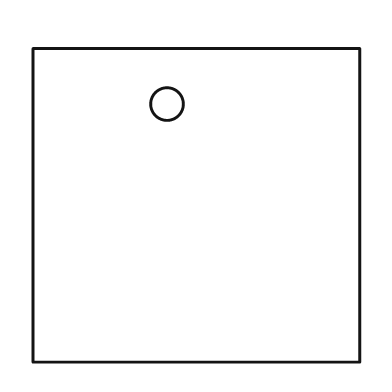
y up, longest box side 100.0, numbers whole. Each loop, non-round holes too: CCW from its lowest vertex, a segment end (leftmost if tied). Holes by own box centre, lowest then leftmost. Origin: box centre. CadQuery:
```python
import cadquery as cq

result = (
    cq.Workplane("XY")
    .moveTo(-50.0, -48.0)
    .lineTo(50.0, -48.0)
    .lineTo(50.0, 48.0)
    .lineTo(-50.0, 48.0)
    .close()
    .moveTo(-9.0, 31.0)
    .circle(5.0)
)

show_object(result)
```